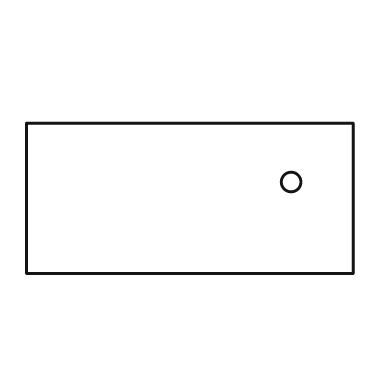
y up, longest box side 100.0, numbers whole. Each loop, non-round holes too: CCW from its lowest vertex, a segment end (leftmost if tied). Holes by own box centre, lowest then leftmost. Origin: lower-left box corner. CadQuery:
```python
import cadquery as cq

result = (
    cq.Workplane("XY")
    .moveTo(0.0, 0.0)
    .lineTo(100.0, 0.0)
    .lineTo(100.0, 46.0)
    .lineTo(0.0, 46.0)
    .close()
    .moveTo(81.0, 28.0)
    .circle(3.0)
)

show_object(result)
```